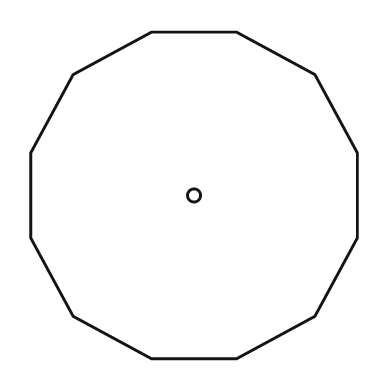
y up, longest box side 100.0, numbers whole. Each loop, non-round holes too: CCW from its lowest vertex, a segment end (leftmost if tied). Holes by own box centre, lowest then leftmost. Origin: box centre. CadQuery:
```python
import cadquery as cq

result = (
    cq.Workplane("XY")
    .moveTo(-13.0, -50.0)
    .lineTo(13.0, -50.0)
    .lineTo(37.0, -37.0)
    .lineTo(50.0, -13.0)
    .lineTo(50.0, 13.0)
    .lineTo(37.0, 37.0)
    .lineTo(13.0, 50.0)
    .lineTo(-13.0, 50.0)
    .lineTo(-37.0, 37.0)
    .lineTo(-50.0, 13.0)
    .lineTo(-50.0, -13.0)
    .lineTo(-37.0, -37.0)
    .close()
    .moveTo(0.0, 0.0)
    .circle(2.0)
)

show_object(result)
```